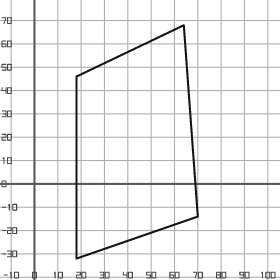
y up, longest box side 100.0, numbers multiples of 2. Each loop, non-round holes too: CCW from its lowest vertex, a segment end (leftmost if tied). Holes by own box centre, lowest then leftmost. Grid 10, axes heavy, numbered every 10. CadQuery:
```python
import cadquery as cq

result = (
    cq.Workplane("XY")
    .moveTo(18.0, -32.0)
    .lineTo(70.0, -14.0)
    .lineTo(64.0, 68.0)
    .lineTo(18.0, 46.0)
    .close()
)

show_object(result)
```